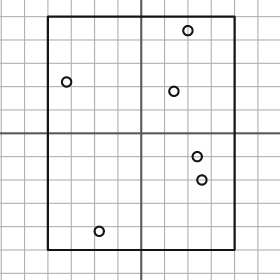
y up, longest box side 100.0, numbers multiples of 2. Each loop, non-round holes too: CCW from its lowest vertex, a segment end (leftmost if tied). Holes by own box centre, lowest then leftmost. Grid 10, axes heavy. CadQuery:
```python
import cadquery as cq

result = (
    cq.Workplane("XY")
    .moveTo(-40.0, -50.0)
    .lineTo(40.0, -50.0)
    .lineTo(40.0, 50.0)
    .lineTo(-40.0, 50.0)
    .close()
    .moveTo(-18.0, -42.0)
    .circle(2.0)
    .moveTo(26.0, -20.0)
    .circle(2.0)
    .moveTo(24.0, -10.0)
    .circle(2.0)
    .moveTo(14.0, 18.0)
    .circle(2.0)
    .moveTo(-32.0, 22.0)
    .circle(2.0)
    .moveTo(20.0, 44.0)
    .circle(2.0)
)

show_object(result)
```